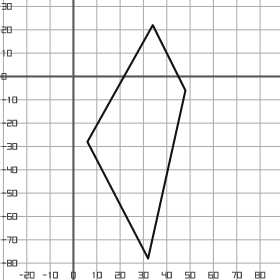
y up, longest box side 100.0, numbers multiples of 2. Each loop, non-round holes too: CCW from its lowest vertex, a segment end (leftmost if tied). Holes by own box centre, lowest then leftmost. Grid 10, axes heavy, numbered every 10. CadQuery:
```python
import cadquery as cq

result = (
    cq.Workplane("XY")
    .moveTo(32.0, -78.0)
    .lineTo(48.0, -6.0)
    .lineTo(34.0, 22.0)
    .lineTo(6.0, -28.0)
    .close()
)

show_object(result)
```